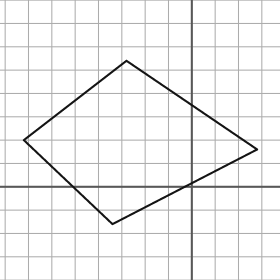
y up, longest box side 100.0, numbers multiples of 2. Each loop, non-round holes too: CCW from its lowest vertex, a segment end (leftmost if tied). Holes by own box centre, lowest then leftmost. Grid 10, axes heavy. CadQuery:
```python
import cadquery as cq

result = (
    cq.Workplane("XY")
    .moveTo(-34.0, -16.0)
    .lineTo(28.0, 16.0)
    .lineTo(-28.0, 54.0)
    .lineTo(-72.0, 20.0)
    .close()
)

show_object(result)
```